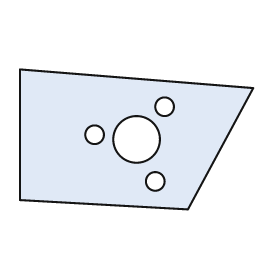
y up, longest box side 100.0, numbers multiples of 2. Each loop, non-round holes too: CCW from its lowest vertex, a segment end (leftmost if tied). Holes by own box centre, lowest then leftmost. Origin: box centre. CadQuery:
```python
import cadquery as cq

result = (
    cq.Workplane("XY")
    .moveTo(22.0, -30.0)
    .lineTo(50.0, 22.0)
    .lineTo(-50.0, 30.0)
    .lineTo(-50.0, -26.0)
    .close()
    .moveTo(8.0, -18.0)
    .circle(4.0)
    .moveTo(0.0, 0.0)
    .circle(10.0)
    .moveTo(-18.0, 2.0)
    .circle(4.0)
    .moveTo(12.0, 14.0)
    .circle(4.0)
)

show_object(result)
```